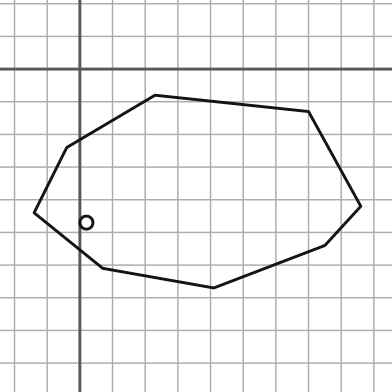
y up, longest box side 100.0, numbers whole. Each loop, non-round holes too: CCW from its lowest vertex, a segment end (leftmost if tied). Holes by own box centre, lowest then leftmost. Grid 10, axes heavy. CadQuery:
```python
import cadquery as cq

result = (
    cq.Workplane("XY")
    .moveTo(41.0, -67.0)
    .lineTo(75.0, -54.0)
    .lineTo(86.0, -42.0)
    .lineTo(70.0, -13.0)
    .lineTo(23.0, -8.0)
    .lineTo(-4.0, -24.0)
    .lineTo(-14.0, -44.0)
    .lineTo(7.0, -61.0)
    .close()
    .moveTo(2.0, -47.0)
    .circle(2.0)
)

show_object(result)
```